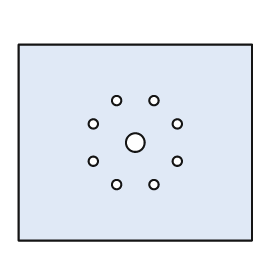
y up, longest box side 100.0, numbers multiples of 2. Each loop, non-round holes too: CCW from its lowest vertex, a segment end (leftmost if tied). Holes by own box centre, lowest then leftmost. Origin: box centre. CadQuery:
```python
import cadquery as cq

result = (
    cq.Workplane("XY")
    .moveTo(-50.0, -42.0)
    .lineTo(50.0, -42.0)
    .lineTo(50.0, 42.0)
    .lineTo(-50.0, 42.0)
    .close()
    .moveTo(-8.0, -18.0)
    .circle(2.0)
    .moveTo(8.0, -18.0)
    .circle(2.0)
    .moveTo(-18.0, -8.0)
    .circle(2.0)
    .moveTo(18.0, -8.0)
    .circle(2.0)
    .moveTo(0.0, 0.0)
    .circle(4.0)
    .moveTo(-18.0, 8.0)
    .circle(2.0)
    .moveTo(18.0, 8.0)
    .circle(2.0)
    .moveTo(-8.0, 18.0)
    .circle(2.0)
    .moveTo(8.0, 18.0)
    .circle(2.0)
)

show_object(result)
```